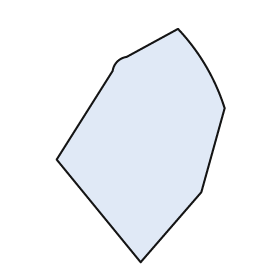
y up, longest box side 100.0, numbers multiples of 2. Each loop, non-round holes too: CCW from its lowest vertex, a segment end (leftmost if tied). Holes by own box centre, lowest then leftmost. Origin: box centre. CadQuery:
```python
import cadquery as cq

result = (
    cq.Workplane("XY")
    .moveTo(0.0, -50.0)
    .lineTo(26.0, -20.0)
    .lineTo(36.0, 16.0)
    .threePointArc((28.0, 34.0), (16.0, 50.0))
    .lineTo(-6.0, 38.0)
    .threePointArc((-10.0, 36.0), (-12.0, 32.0))
    .lineTo(-36.0, -6.0)
    .close()
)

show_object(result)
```